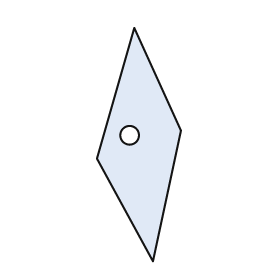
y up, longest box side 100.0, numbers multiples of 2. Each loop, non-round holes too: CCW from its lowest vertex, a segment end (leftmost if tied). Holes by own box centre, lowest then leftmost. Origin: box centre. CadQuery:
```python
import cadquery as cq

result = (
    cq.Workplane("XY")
    .moveTo(6.0, -50.0)
    .lineTo(18.0, 6.0)
    .lineTo(-2.0, 50.0)
    .lineTo(-18.0, -6.0)
    .close()
    .moveTo(-4.0, 4.0)
    .circle(4.0)
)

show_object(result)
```